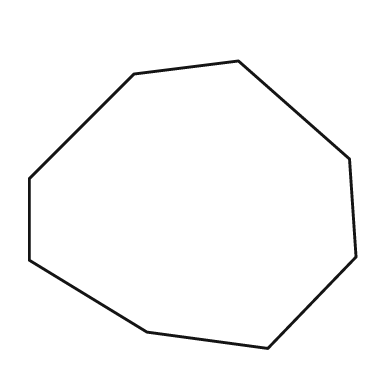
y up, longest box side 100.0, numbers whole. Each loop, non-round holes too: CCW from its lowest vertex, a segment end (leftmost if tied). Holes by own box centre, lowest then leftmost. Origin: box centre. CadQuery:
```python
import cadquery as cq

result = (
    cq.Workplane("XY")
    .moveTo(23.0, -44.0)
    .lineTo(50.0, -16.0)
    .lineTo(48.0, 14.0)
    .lineTo(14.0, 44.0)
    .lineTo(-18.0, 40.0)
    .lineTo(-50.0, 8.0)
    .lineTo(-50.0, -17.0)
    .lineTo(-14.0, -39.0)
    .close()
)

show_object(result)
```